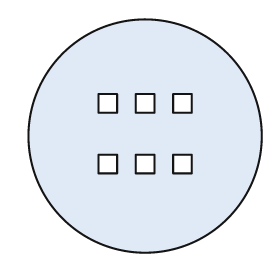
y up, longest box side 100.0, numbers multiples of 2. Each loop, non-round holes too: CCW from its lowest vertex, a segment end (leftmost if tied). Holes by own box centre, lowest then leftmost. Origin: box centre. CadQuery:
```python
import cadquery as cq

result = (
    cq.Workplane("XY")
    .moveTo(0.0, 0.0)
    .circle(50.0)
    .moveTo(-20.0, -16.0)
    .lineTo(-12.0, -16.0)
    .lineTo(-12.0, -8.0)
    .lineTo(-20.0, -8.0)
    .close()
    .moveTo(-4.0, -16.0)
    .lineTo(4.0, -16.0)
    .lineTo(4.0, -8.0)
    .lineTo(-4.0, -8.0)
    .close()
    .moveTo(12.0, -16.0)
    .lineTo(20.0, -16.0)
    .lineTo(20.0, -8.0)
    .lineTo(12.0, -8.0)
    .close()
    .moveTo(-20.0, 10.0)
    .lineTo(-12.0, 10.0)
    .lineTo(-12.0, 18.0)
    .lineTo(-20.0, 18.0)
    .close()
    .moveTo(-4.0, 10.0)
    .lineTo(4.0, 10.0)
    .lineTo(4.0, 18.0)
    .lineTo(-4.0, 18.0)
    .close()
    .moveTo(12.0, 10.0)
    .lineTo(20.0, 10.0)
    .lineTo(20.0, 18.0)
    .lineTo(12.0, 18.0)
    .close()
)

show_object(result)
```